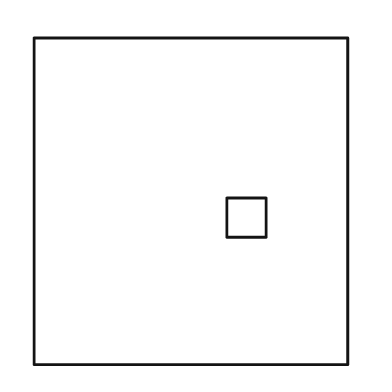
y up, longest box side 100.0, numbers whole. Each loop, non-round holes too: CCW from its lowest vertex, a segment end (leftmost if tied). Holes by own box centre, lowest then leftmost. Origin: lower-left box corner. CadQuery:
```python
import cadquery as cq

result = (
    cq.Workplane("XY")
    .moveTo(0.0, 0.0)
    .lineTo(96.0, 0.0)
    .lineTo(96.0, 100.0)
    .lineTo(0.0, 100.0)
    .close()
    .moveTo(59.0, 39.0)
    .lineTo(71.0, 39.0)
    .lineTo(71.0, 51.0)
    .lineTo(59.0, 51.0)
    .close()
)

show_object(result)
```